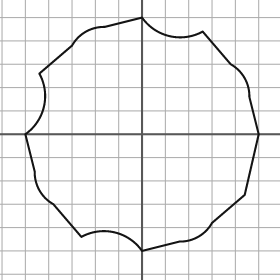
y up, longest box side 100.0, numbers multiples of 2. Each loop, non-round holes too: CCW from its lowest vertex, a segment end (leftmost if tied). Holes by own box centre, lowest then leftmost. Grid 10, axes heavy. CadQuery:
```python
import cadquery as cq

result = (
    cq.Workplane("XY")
    .moveTo(0.0, -50.0)
    .lineTo(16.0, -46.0)
    .threePointArc((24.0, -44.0), (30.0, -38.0))
    .lineTo(44.0, -26.0)
    .lineTo(50.0, 0.0)
    .lineTo(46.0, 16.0)
    .threePointArc((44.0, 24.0), (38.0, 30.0))
    .lineTo(26.0, 44.0)
    .threePointArc((12.0, 42.0), (0.0, 50.0))
    .lineTo(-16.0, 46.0)
    .threePointArc((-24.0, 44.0), (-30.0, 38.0))
    .lineTo(-44.0, 26.0)
    .threePointArc((-42.0, 12.0), (-50.0, 0.0))
    .lineTo(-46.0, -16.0)
    .threePointArc((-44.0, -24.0), (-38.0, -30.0))
    .lineTo(-26.0, -44.0)
    .threePointArc((-12.0, -42.0), (0.0, -50.0))
    .close()
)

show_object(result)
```